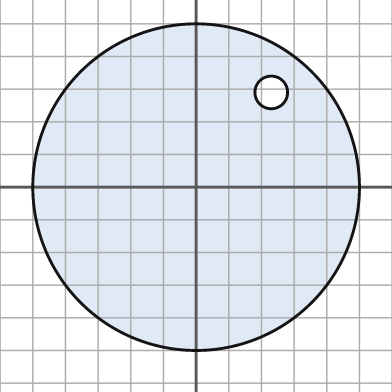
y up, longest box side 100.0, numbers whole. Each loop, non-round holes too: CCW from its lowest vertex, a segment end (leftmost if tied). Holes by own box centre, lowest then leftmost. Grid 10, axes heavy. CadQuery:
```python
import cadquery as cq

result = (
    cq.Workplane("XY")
    .moveTo(0.0, 0.0)
    .circle(50.0)
    .moveTo(23.0, 29.0)
    .circle(5.0)
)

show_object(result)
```